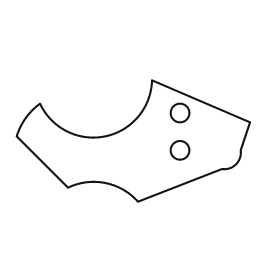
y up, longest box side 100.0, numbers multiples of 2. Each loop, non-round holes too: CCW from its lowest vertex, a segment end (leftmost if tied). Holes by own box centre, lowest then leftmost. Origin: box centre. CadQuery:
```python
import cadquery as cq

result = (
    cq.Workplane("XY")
    .moveTo(2.0, -26.0)
    .lineTo(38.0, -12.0)
    .threePointArc((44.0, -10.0), (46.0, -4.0))
    .lineTo(50.0, 8.0)
    .lineTo(8.0, 26.0)
    .threePointArc((-12.0, 2.0), (-40.0, 16.0))
    .threePointArc((-46.0, 10.0), (-50.0, 2.0))
    .lineTo(-28.0, -20.0)
    .threePointArc((-12.0, -18.0), (2.0, -26.0))
    .close()
    .moveTo(20.0, -4.0)
    .circle(4.0)
    .moveTo(20.0, 12.0)
    .circle(4.0)
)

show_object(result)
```